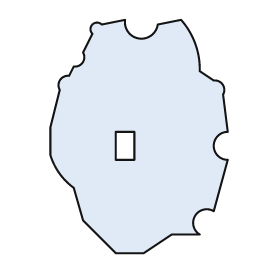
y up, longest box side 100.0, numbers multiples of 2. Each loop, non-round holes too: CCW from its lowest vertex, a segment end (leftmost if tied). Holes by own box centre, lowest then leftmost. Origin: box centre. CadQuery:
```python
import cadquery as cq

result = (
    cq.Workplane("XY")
    .moveTo(-10.0, -50.0)
    .lineTo(2.0, -50.0)
    .lineTo(14.0, -42.0)
    .lineTo(26.0, -42.0)
    .threePointArc((24.0, -34.0), (32.0, -32.0))
    .lineTo(38.0, -10.0)
    .threePointArc((32.0, -4.0), (38.0, 2.0))
    .lineTo(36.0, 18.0)
    .threePointArc((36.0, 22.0), (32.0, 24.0))
    .lineTo(26.0, 28.0)
    .threePointArc((24.0, 40.0), (18.0, 50.0))
    .lineTo(8.0, 48.0)
    .threePointArc((0.0, 42.0), (-6.0, 50.0))
    .lineTo(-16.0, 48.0)
    .threePointArc((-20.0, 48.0), (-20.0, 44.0))
    .lineTo(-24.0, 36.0)
    .threePointArc((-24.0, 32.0), (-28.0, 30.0))
    .lineTo(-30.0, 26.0)
    .threePointArc((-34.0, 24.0), (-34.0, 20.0))
    .lineTo(-38.0, 4.0)
    .lineTo(-38.0, -8.0)
    .threePointArc((-34.0, -16.0), (-28.0, -22.0))
    .lineTo(-24.0, -36.0)
    .close()
    .moveTo(-10.0, -10.0)
    .lineTo(-2.0, -10.0)
    .lineTo(-2.0, 2.0)
    .lineTo(-10.0, 2.0)
    .close()
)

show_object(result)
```